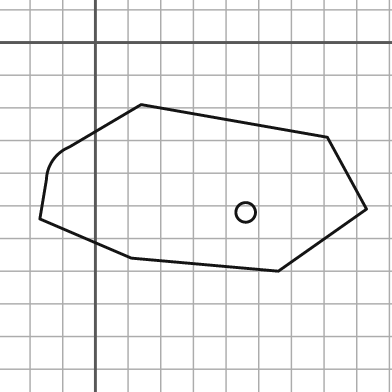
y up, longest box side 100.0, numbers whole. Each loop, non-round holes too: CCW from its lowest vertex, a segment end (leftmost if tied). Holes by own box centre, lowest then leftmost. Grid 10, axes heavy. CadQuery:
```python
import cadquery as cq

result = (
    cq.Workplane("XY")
    .moveTo(56.0, -70.0)
    .lineTo(83.0, -51.0)
    .lineTo(71.0, -29.0)
    .lineTo(14.0, -19.0)
    .lineTo(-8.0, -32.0)
    .threePointArc((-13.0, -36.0), (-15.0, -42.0))
    .lineTo(-17.0, -54.0)
    .lineTo(11.0, -66.0)
    .close()
    .moveTo(46.0, -52.0)
    .circle(3.0)
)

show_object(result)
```